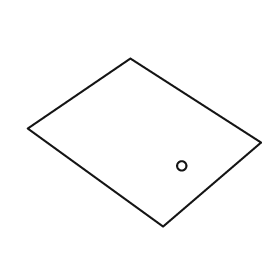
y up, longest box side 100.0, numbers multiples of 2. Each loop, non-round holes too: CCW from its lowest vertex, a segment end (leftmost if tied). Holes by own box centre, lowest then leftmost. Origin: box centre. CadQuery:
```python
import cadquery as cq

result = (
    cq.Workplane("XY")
    .moveTo(8.0, -36.0)
    .lineTo(50.0, 0.0)
    .lineTo(-6.0, 36.0)
    .lineTo(-50.0, 6.0)
    .close()
    .moveTo(16.0, -10.0)
    .circle(2.0)
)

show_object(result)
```